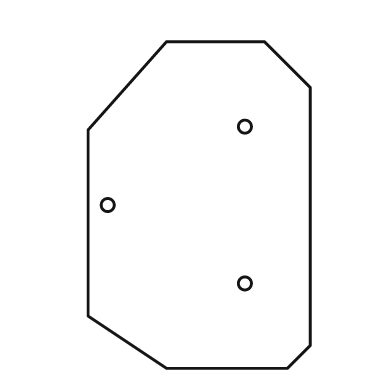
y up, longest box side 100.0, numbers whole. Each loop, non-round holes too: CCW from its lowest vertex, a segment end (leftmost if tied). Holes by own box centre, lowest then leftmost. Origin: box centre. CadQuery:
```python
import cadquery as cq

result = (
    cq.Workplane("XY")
    .moveTo(-10.0, -50.0)
    .lineTo(27.0, -50.0)
    .lineTo(34.0, -43.0)
    .lineTo(34.0, 36.0)
    .lineTo(20.0, 50.0)
    .lineTo(-10.0, 50.0)
    .lineTo(-34.0, 23.0)
    .lineTo(-34.0, -34.0)
    .close()
    .moveTo(14.0, -24.0)
    .circle(2.0)
    .moveTo(-28.0, 0.0)
    .circle(2.0)
    .moveTo(14.0, 24.0)
    .circle(2.0)
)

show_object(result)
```